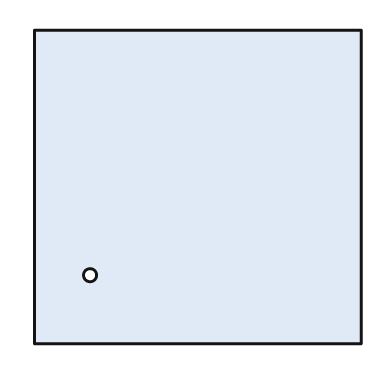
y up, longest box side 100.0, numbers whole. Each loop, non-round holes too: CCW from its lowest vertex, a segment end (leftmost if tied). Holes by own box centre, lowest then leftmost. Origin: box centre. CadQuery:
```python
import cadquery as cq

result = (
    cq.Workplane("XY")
    .moveTo(-50.0, -48.0)
    .lineTo(50.0, -48.0)
    .lineTo(50.0, 48.0)
    .lineTo(-50.0, 48.0)
    .close()
    .moveTo(-33.0, -27.0)
    .circle(2.0)
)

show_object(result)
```